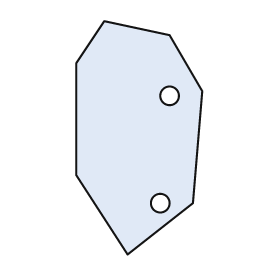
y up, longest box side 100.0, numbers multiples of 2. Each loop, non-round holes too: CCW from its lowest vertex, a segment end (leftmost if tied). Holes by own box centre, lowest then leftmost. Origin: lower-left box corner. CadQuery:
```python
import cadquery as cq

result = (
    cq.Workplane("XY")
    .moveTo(22.0, 0.0)
    .lineTo(50.0, 22.0)
    .lineTo(54.0, 70.0)
    .lineTo(40.0, 94.0)
    .lineTo(12.0, 100.0)
    .lineTo(0.0, 82.0)
    .lineTo(0.0, 34.0)
    .close()
    .moveTo(36.0, 22.0)
    .circle(4.0)
    .moveTo(40.0, 68.0)
    .circle(4.0)
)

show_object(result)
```